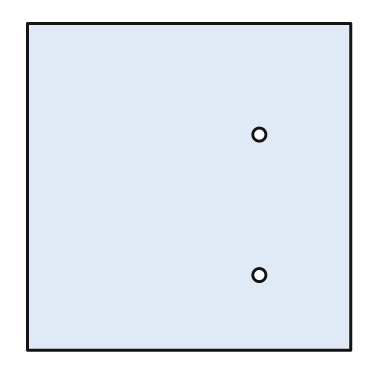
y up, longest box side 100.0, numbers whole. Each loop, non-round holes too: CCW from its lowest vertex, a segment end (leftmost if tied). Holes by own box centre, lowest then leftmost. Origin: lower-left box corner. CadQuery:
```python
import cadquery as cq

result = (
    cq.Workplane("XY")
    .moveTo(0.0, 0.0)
    .lineTo(99.0, 0.0)
    .lineTo(99.0, 100.0)
    .lineTo(0.0, 100.0)
    .close()
    .moveTo(71.0, 23.0)
    .circle(2.0)
    .moveTo(71.0, 66.0)
    .circle(2.0)
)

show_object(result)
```